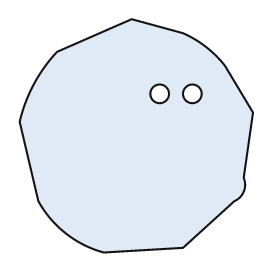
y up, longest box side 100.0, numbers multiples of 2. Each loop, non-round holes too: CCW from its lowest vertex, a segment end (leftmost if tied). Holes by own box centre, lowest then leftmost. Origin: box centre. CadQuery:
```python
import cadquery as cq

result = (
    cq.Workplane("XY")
    .moveTo(-14.0, -50.0)
    .lineTo(20.0, -48.0)
    .lineTo(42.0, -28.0)
    .threePointArc((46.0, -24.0), (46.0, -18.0))
    .lineTo(50.0, 10.0)
    .lineTo(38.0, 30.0)
    .threePointArc((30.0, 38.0), (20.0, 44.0))
    .lineTo(-2.0, 50.0)
    .lineTo(-34.0, 36.0)
    .threePointArc((-44.0, 22.0), (-50.0, 6.0))
    .lineTo(-42.0, -28.0)
    .threePointArc((-30.0, -42.0), (-14.0, -50.0))
    .close()
    .moveTo(10.0, 18.0)
    .circle(4.0)
    .moveTo(24.0, 18.0)
    .circle(4.0)
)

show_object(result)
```